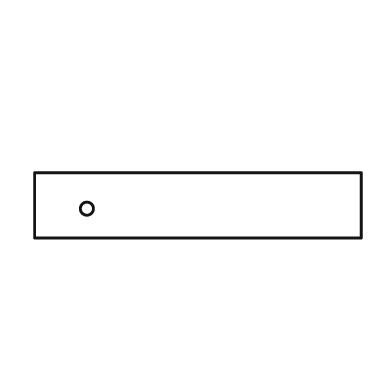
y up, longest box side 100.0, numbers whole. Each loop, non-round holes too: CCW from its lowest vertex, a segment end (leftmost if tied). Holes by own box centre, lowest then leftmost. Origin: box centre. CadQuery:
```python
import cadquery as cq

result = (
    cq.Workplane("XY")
    .moveTo(-50.0, -10.0)
    .lineTo(50.0, -10.0)
    .lineTo(50.0, 10.0)
    .lineTo(-50.0, 10.0)
    .close()
    .moveTo(-34.0, -1.0)
    .circle(2.0)
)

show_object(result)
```